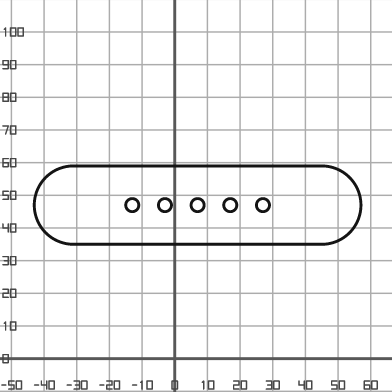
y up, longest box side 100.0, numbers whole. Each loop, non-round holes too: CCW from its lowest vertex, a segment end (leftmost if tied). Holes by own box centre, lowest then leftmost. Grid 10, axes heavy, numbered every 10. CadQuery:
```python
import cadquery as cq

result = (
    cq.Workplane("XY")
    .moveTo(-31.0, 35.0)
    .lineTo(45.0, 35.0)
    .threePointArc((57.0, 47.0), (45.0, 59.0))
    .lineTo(-31.0, 59.0)
    .threePointArc((-43.0, 47.0), (-31.0, 35.0))
    .close()
    .moveTo(-13.0, 47.0)
    .circle(2.0)
    .moveTo(-3.0, 47.0)
    .circle(2.0)
    .moveTo(7.0, 47.0)
    .circle(2.0)
    .moveTo(17.0, 47.0)
    .circle(2.0)
    .moveTo(27.0, 47.0)
    .circle(2.0)
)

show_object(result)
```